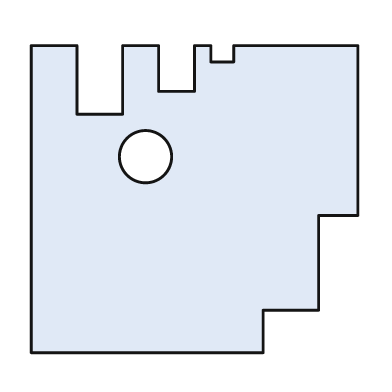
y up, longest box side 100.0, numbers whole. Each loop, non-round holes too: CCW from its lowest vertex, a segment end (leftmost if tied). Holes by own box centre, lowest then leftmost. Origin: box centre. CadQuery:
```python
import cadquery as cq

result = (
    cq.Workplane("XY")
    .moveTo(-50.0, -47.0)
    .lineTo(21.0, -47.0)
    .lineTo(21.0, -34.0)
    .lineTo(38.0, -34.0)
    .lineTo(38.0, -5.0)
    .lineTo(50.0, -5.0)
    .lineTo(50.0, 47.0)
    .lineTo(12.0, 47.0)
    .lineTo(12.0, 42.0)
    .lineTo(5.0, 42.0)
    .lineTo(5.0, 47.0)
    .lineTo(0.0, 47.0)
    .lineTo(0.0, 33.0)
    .lineTo(-11.0, 33.0)
    .lineTo(-11.0, 47.0)
    .lineTo(-22.0, 47.0)
    .lineTo(-22.0, 26.0)
    .lineTo(-36.0, 26.0)
    .lineTo(-36.0, 47.0)
    .lineTo(-50.0, 47.0)
    .close()
    .moveTo(-15.0, 13.0)
    .circle(8.0)
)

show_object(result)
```